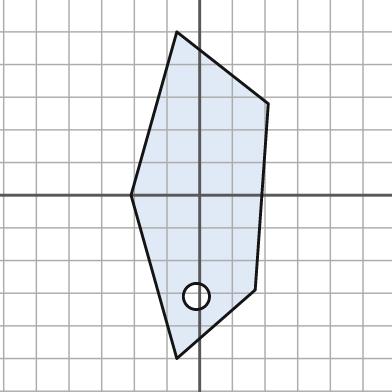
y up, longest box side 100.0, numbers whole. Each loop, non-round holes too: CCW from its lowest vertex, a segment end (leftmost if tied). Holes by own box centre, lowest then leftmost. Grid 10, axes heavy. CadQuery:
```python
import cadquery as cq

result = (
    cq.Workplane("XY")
    .moveTo(-7.0, -50.0)
    .lineTo(17.0, -29.0)
    .lineTo(21.0, 28.0)
    .lineTo(-7.0, 50.0)
    .lineTo(-21.0, 0.0)
    .close()
    .moveTo(-1.0, -31.0)
    .circle(4.0)
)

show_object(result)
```